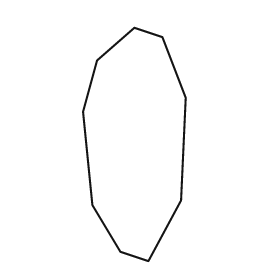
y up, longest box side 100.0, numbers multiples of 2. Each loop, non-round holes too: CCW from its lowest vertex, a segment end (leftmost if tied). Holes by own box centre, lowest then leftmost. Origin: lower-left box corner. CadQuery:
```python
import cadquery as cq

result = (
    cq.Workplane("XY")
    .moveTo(28.0, 0.0)
    .lineTo(42.0, 26.0)
    .lineTo(44.0, 70.0)
    .lineTo(34.0, 96.0)
    .lineTo(22.0, 100.0)
    .lineTo(6.0, 86.0)
    .lineTo(0.0, 64.0)
    .lineTo(4.0, 24.0)
    .lineTo(16.0, 4.0)
    .close()
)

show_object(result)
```